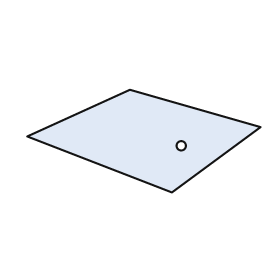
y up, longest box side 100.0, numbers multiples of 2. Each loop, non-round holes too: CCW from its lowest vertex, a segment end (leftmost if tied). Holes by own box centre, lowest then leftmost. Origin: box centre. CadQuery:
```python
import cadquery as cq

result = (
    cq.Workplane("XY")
    .moveTo(12.0, -22.0)
    .lineTo(50.0, 6.0)
    .lineTo(-6.0, 22.0)
    .lineTo(-50.0, 2.0)
    .close()
    .moveTo(16.0, -2.0)
    .circle(2.0)
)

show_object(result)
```